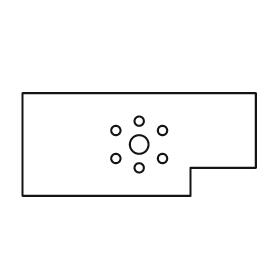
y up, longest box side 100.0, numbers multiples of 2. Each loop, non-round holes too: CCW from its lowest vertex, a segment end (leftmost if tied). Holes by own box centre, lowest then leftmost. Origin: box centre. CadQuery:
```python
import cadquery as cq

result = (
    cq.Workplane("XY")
    .moveTo(-50.0, -22.0)
    .lineTo(22.0, -22.0)
    .lineTo(22.0, -10.0)
    .lineTo(50.0, -10.0)
    .lineTo(50.0, 22.0)
    .lineTo(-50.0, 22.0)
    .close()
    .moveTo(0.0, -10.0)
    .circle(2.0)
    .moveTo(-10.0, -6.0)
    .circle(2.0)
    .moveTo(10.0, -6.0)
    .circle(2.0)
    .moveTo(0.0, 0.0)
    .circle(4.0)
    .moveTo(-10.0, 6.0)
    .circle(2.0)
    .moveTo(10.0, 6.0)
    .circle(2.0)
    .moveTo(0.0, 10.0)
    .circle(2.0)
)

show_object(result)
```